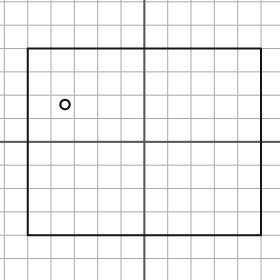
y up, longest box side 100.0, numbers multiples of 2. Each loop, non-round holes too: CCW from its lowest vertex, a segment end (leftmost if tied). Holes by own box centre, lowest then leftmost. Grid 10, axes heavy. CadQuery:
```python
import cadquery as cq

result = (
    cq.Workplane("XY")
    .moveTo(-50.0, -40.0)
    .lineTo(50.0, -40.0)
    .lineTo(50.0, 40.0)
    .lineTo(-50.0, 40.0)
    .close()
    .moveTo(-34.0, 16.0)
    .circle(2.0)
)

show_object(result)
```